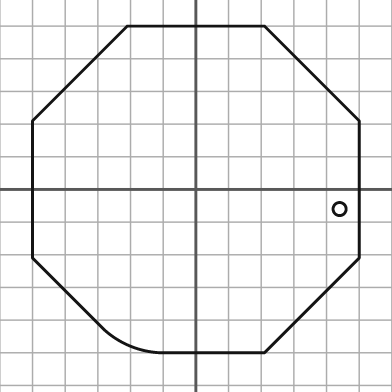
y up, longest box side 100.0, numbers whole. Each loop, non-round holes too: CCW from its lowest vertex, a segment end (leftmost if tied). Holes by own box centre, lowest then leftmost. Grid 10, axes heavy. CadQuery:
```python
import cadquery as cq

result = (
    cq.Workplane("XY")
    .moveTo(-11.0, -50.0)
    .lineTo(21.0, -50.0)
    .lineTo(50.0, -21.0)
    .lineTo(50.0, 21.0)
    .lineTo(21.0, 50.0)
    .lineTo(-21.0, 50.0)
    .lineTo(-50.0, 21.0)
    .lineTo(-50.0, -21.0)
    .lineTo(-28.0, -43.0)
    .threePointArc((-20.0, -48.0), (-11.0, -50.0))
    .close()
    .moveTo(44.0, -6.0)
    .circle(2.0)
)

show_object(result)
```